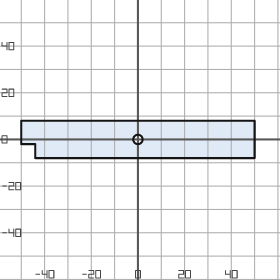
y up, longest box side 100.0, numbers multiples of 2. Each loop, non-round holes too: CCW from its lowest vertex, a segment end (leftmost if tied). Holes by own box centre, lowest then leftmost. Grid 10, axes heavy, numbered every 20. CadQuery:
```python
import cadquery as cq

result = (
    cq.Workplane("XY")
    .moveTo(-44.0, -8.0)
    .lineTo(50.0, -8.0)
    .lineTo(50.0, 8.0)
    .lineTo(-50.0, 8.0)
    .lineTo(-50.0, -2.0)
    .lineTo(-44.0, -2.0)
    .close()
    .moveTo(0.0, 0.0)
    .circle(2.0)
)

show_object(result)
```